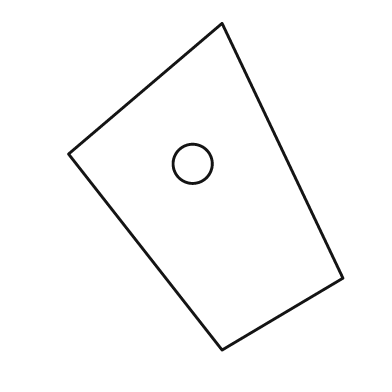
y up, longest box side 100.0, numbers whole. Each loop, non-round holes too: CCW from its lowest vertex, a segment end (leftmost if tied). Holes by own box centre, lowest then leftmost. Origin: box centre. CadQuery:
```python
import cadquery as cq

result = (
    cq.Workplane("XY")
    .moveTo(5.0, -50.0)
    .lineTo(42.0, -28.0)
    .lineTo(5.0, 50.0)
    .lineTo(-42.0, 10.0)
    .close()
    .moveTo(-4.0, 7.0)
    .circle(6.0)
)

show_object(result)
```